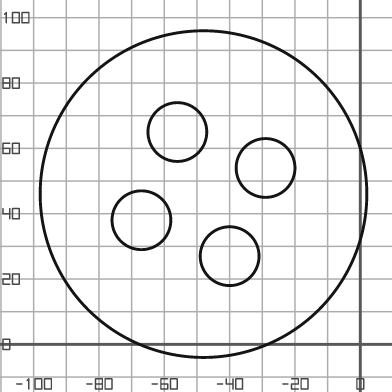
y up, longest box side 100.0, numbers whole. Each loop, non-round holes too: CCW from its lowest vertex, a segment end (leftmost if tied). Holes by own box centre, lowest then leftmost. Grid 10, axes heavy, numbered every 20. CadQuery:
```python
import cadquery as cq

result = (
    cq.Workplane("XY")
    .moveTo(-48.0, 46.0)
    .circle(50.0)
    .moveTo(-40.0, 27.0)
    .circle(9.0)
    .moveTo(-67.0, 38.0)
    .circle(9.0)
    .moveTo(-29.0, 54.0)
    .circle(9.0)
    .moveTo(-56.0, 65.0)
    .circle(9.0)
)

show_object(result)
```